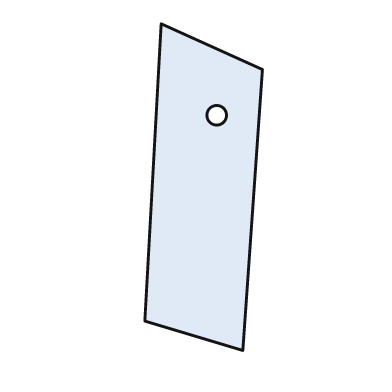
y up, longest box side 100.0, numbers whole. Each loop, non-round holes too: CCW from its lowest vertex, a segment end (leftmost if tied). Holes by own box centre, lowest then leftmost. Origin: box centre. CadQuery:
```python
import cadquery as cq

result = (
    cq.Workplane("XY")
    .moveTo(12.0, -50.0)
    .lineTo(18.0, 36.0)
    .lineTo(-13.0, 50.0)
    .lineTo(-18.0, -41.0)
    .close()
    .moveTo(4.0, 22.0)
    .circle(3.0)
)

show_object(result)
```